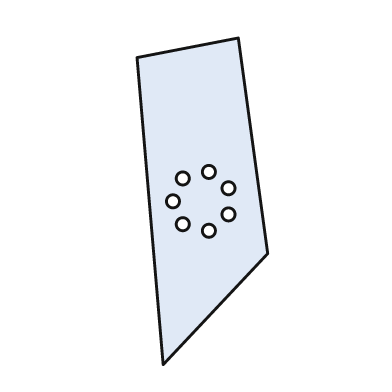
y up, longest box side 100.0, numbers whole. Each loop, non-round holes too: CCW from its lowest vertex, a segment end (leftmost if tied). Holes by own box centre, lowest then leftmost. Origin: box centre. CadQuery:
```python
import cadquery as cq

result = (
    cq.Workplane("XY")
    .moveTo(-12.0, -50.0)
    .lineTo(20.0, -16.0)
    .lineTo(11.0, 50.0)
    .lineTo(-20.0, 44.0)
    .close()
    .moveTo(2.0, -9.0)
    .circle(2.0)
    .moveTo(-6.0, -7.0)
    .circle(2.0)
    .moveTo(8.0, -4.0)
    .circle(2.0)
    .moveTo(-9.0, 0.0)
    .circle(2.0)
    .moveTo(8.0, 4.0)
    .circle(2.0)
    .moveTo(-6.0, 7.0)
    .circle(2.0)
    .moveTo(2.0, 9.0)
    .circle(2.0)
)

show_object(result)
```